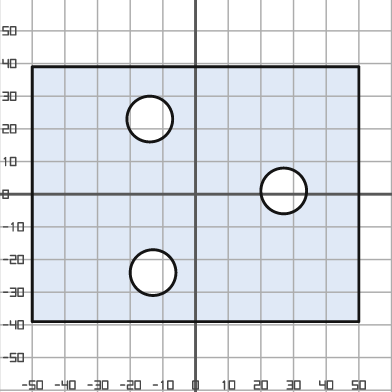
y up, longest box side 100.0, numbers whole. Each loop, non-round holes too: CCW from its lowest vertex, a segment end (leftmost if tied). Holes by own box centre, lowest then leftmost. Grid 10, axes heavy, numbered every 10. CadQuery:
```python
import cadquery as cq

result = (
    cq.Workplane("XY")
    .moveTo(-50.0, -39.0)
    .lineTo(50.0, -39.0)
    .lineTo(50.0, 39.0)
    .lineTo(-50.0, 39.0)
    .close()
    .moveTo(-13.0, -24.0)
    .circle(7.0)
    .moveTo(27.0, 1.0)
    .circle(7.0)
    .moveTo(-14.0, 23.0)
    .circle(7.0)
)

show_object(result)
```